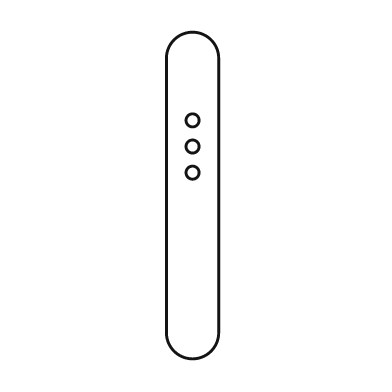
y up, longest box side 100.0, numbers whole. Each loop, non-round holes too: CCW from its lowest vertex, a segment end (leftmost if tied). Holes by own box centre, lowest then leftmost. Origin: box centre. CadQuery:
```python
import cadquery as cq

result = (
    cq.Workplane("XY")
    .moveTo(-8.0, -42.0)
    .threePointArc((0.0, -50.0), (8.0, -42.0))
    .lineTo(8.0, 42.0)
    .threePointArc((0.0, 50.0), (-8.0, 42.0))
    .close()
    .moveTo(0.0, 7.0)
    .circle(2.0)
    .moveTo(0.0, 15.0)
    .circle(2.0)
    .moveTo(0.0, 23.0)
    .circle(2.0)
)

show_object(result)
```